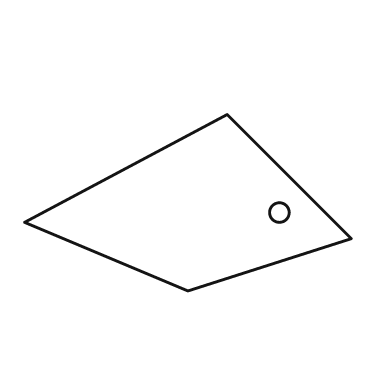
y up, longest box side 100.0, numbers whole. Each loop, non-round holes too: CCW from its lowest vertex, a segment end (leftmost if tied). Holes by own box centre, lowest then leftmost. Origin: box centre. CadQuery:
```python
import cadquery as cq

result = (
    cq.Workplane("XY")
    .moveTo(0.0, -27.0)
    .lineTo(50.0, -11.0)
    .lineTo(12.0, 27.0)
    .lineTo(-50.0, -6.0)
    .close()
    .moveTo(28.0, -3.0)
    .circle(3.0)
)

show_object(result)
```